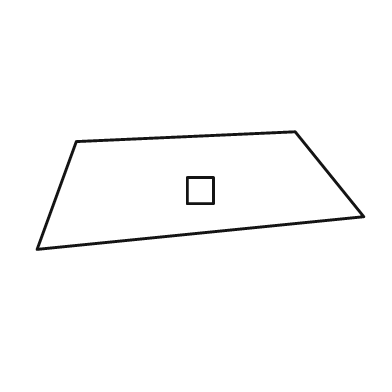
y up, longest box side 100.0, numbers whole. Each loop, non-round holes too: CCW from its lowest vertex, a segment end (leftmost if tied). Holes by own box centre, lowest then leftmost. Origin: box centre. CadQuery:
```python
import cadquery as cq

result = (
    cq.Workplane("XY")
    .moveTo(-50.0, -18.0)
    .lineTo(50.0, -8.0)
    .lineTo(29.0, 18.0)
    .lineTo(-38.0, 15.0)
    .close()
    .moveTo(-4.0, -4.0)
    .lineTo(4.0, -4.0)
    .lineTo(4.0, 4.0)
    .lineTo(-4.0, 4.0)
    .close()
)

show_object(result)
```